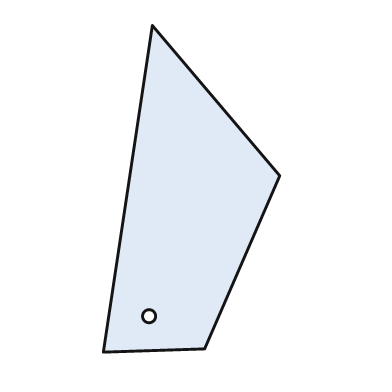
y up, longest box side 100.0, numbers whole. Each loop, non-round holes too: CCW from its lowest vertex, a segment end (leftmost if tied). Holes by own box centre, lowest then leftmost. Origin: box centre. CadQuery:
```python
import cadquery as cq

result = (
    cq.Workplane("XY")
    .moveTo(-27.0, -50.0)
    .lineTo(4.0, -49.0)
    .lineTo(27.0, 4.0)
    .lineTo(-12.0, 50.0)
    .close()
    .moveTo(-13.0, -39.0)
    .circle(2.0)
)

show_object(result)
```